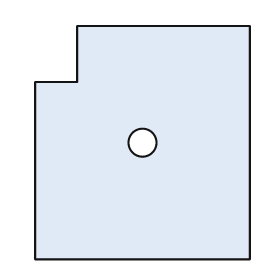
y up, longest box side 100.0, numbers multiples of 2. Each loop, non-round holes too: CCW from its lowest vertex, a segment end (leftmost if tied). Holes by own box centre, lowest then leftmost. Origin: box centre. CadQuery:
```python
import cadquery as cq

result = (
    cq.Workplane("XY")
    .moveTo(-46.0, -50.0)
    .lineTo(46.0, -50.0)
    .lineTo(46.0, 50.0)
    .lineTo(-28.0, 50.0)
    .lineTo(-28.0, 26.0)
    .lineTo(-46.0, 26.0)
    .close()
    .moveTo(0.0, 0.0)
    .circle(6.0)
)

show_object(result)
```